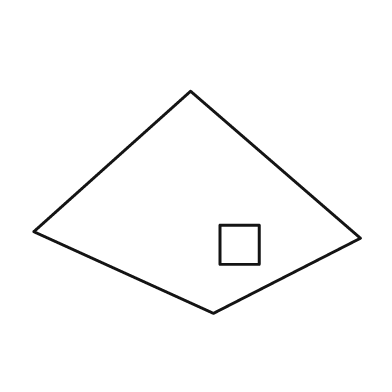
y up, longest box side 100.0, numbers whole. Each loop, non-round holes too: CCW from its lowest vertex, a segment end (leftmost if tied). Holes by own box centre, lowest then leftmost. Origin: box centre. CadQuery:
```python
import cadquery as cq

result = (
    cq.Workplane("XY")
    .moveTo(5.0, -34.0)
    .lineTo(50.0, -11.0)
    .lineTo(-2.0, 34.0)
    .lineTo(-50.0, -9.0)
    .close()
    .moveTo(7.0, -19.0)
    .lineTo(19.0, -19.0)
    .lineTo(19.0, -7.0)
    .lineTo(7.0, -7.0)
    .close()
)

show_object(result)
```